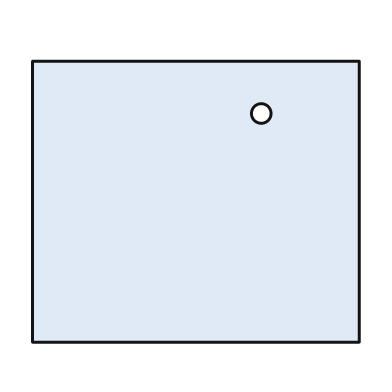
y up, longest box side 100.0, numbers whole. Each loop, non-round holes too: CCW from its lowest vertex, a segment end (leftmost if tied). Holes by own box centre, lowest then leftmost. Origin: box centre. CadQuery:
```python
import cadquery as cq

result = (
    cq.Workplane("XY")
    .moveTo(-50.0, -43.0)
    .lineTo(50.0, -43.0)
    .lineTo(50.0, 43.0)
    .lineTo(-50.0, 43.0)
    .close()
    .moveTo(20.0, 27.0)
    .circle(3.0)
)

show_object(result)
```